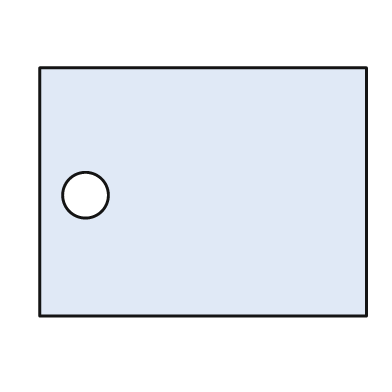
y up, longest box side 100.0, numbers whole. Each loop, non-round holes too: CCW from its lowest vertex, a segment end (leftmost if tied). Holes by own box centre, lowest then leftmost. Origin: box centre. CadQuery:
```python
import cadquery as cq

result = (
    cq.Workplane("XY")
    .moveTo(-50.0, -38.0)
    .lineTo(50.0, -38.0)
    .lineTo(50.0, 38.0)
    .lineTo(-50.0, 38.0)
    .close()
    .moveTo(-36.0, -1.0)
    .circle(7.0)
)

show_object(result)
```